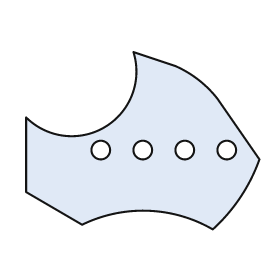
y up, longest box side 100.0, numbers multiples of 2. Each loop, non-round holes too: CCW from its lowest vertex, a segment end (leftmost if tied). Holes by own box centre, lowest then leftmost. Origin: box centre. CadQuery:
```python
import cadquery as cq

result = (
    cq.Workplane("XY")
    .moveTo(30.0, -38.0)
    .threePointArc((42.0, -24.0), (50.0, -8.0))
    .lineTo(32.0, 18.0)
    .threePointArc((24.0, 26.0), (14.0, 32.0))
    .lineTo(-4.0, 38.0)
    .threePointArc((-16.0, 6.0), (-50.0, 10.0))
    .lineTo(-50.0, -22.0)
    .lineTo(-26.0, -36.0)
    .threePointArc((2.0, -30.0), (30.0, -38.0))
    .close()
    .moveTo(-18.0, -4.0)
    .circle(4.0)
    .moveTo(0.0, -4.0)
    .circle(4.0)
    .moveTo(18.0, -4.0)
    .circle(4.0)
    .moveTo(36.0, -4.0)
    .circle(4.0)
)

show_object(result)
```